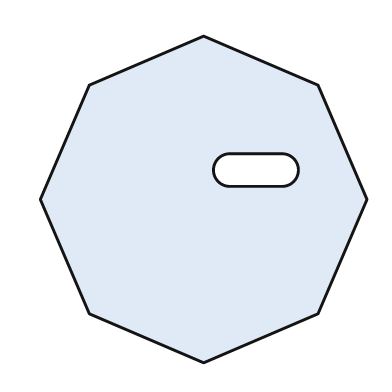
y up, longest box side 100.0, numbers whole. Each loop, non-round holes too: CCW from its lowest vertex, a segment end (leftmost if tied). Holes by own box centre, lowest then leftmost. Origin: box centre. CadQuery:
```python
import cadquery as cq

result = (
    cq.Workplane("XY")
    .moveTo(0.0, -50.0)
    .lineTo(35.0, -35.0)
    .lineTo(50.0, 0.0)
    .lineTo(35.0, 35.0)
    .lineTo(0.0, 50.0)
    .lineTo(-35.0, 35.0)
    .lineTo(-50.0, 0.0)
    .lineTo(-35.0, -35.0)
    .close()
    .moveTo(8.0, 4.0)
    .lineTo(24.0, 4.0)
    .threePointArc((29.0, 9.0), (24.0, 14.0))
    .lineTo(8.0, 14.0)
    .threePointArc((3.0, 9.0), (8.0, 4.0))
    .close()
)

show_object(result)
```